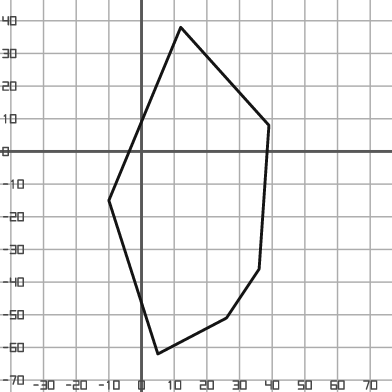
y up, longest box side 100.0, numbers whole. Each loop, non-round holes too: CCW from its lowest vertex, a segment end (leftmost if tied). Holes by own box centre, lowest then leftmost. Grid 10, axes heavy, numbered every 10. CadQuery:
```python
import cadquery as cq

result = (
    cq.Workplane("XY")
    .moveTo(5.0, -62.0)
    .lineTo(26.0, -51.0)
    .lineTo(36.0, -36.0)
    .lineTo(39.0, 8.0)
    .lineTo(12.0, 38.0)
    .lineTo(-10.0, -15.0)
    .close()
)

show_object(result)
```